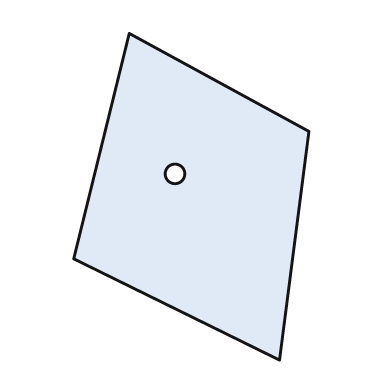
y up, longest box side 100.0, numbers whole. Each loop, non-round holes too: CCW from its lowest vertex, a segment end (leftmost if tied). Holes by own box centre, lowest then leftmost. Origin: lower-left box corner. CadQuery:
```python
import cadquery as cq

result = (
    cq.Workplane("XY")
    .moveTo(63.0, 0.0)
    .lineTo(72.0, 70.0)
    .lineTo(17.0, 100.0)
    .lineTo(0.0, 31.0)
    .close()
    .moveTo(31.0, 57.0)
    .circle(3.0)
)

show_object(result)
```